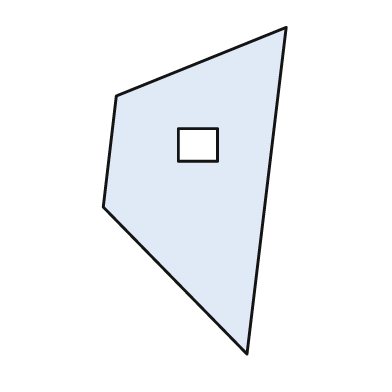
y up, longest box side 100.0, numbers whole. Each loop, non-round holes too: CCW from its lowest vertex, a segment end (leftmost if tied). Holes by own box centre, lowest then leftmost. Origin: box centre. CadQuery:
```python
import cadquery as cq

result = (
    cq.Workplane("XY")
    .moveTo(16.0, -50.0)
    .lineTo(28.0, 50.0)
    .lineTo(-24.0, 29.0)
    .lineTo(-28.0, -5.0)
    .close()
    .moveTo(-5.0, 9.0)
    .lineTo(7.0, 9.0)
    .lineTo(7.0, 19.0)
    .lineTo(-5.0, 19.0)
    .close()
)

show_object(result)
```